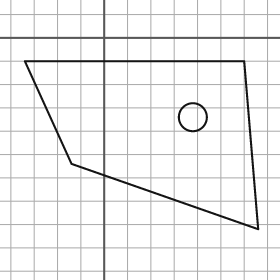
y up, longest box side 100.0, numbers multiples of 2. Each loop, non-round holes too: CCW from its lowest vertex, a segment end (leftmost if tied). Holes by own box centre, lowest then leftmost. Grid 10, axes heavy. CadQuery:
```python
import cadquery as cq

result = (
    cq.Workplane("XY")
    .moveTo(66.0, -82.0)
    .lineTo(60.0, -10.0)
    .lineTo(-34.0, -10.0)
    .lineTo(-14.0, -54.0)
    .close()
    .moveTo(38.0, -34.0)
    .circle(6.0)
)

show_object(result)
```